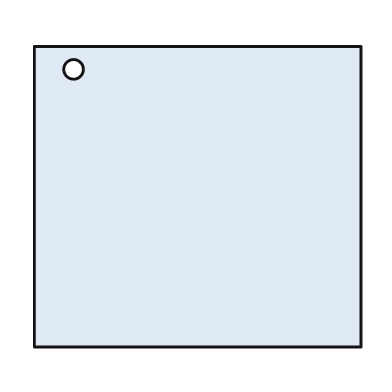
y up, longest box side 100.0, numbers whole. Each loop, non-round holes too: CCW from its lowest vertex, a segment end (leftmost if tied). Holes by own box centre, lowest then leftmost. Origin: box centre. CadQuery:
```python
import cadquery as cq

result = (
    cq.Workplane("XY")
    .moveTo(-50.0, -46.0)
    .lineTo(50.0, -46.0)
    .lineTo(50.0, 46.0)
    .lineTo(-50.0, 46.0)
    .close()
    .moveTo(-38.0, 39.0)
    .circle(3.0)
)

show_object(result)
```